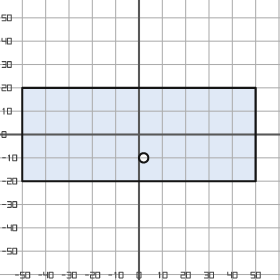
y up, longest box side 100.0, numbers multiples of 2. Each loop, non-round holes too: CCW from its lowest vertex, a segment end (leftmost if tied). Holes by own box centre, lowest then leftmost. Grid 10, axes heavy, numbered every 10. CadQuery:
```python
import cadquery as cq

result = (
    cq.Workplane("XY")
    .moveTo(-50.0, -20.0)
    .lineTo(50.0, -20.0)
    .lineTo(50.0, 20.0)
    .lineTo(-50.0, 20.0)
    .close()
    .moveTo(2.0, -10.0)
    .circle(2.0)
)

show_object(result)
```